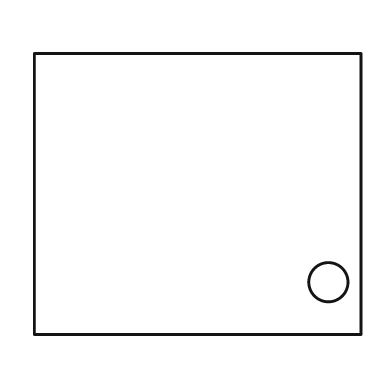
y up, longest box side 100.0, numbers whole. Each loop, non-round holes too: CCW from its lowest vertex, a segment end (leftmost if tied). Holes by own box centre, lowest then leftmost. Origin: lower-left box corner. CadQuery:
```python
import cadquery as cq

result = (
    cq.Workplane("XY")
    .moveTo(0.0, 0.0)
    .lineTo(100.0, 0.0)
    .lineTo(100.0, 86.0)
    .lineTo(0.0, 86.0)
    .close()
    .moveTo(90.0, 16.0)
    .circle(6.0)
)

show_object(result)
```